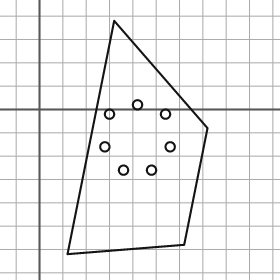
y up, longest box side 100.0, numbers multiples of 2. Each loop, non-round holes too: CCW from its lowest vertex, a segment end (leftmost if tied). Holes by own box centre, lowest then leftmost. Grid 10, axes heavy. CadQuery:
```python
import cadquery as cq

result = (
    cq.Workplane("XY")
    .moveTo(12.0, -62.0)
    .lineTo(62.0, -58.0)
    .lineTo(72.0, -8.0)
    .lineTo(32.0, 38.0)
    .close()
    .moveTo(36.0, -26.0)
    .circle(2.0)
    .moveTo(48.0, -26.0)
    .circle(2.0)
    .moveTo(28.0, -16.0)
    .circle(2.0)
    .moveTo(56.0, -16.0)
    .circle(2.0)
    .moveTo(30.0, -2.0)
    .circle(2.0)
    .moveTo(54.0, -2.0)
    .circle(2.0)
    .moveTo(42.0, 2.0)
    .circle(2.0)
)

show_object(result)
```